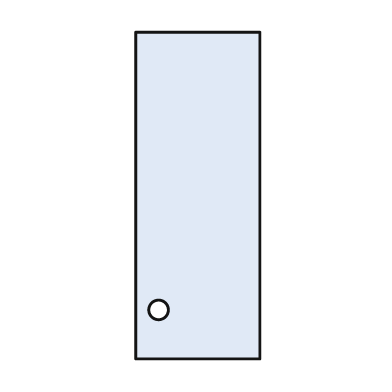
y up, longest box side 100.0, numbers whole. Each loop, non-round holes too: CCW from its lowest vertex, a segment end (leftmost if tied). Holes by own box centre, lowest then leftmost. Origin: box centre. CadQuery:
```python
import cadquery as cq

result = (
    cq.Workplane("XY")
    .moveTo(-19.0, -50.0)
    .lineTo(19.0, -50.0)
    .lineTo(19.0, 50.0)
    .lineTo(-19.0, 50.0)
    .close()
    .moveTo(-12.0, -35.0)
    .circle(3.0)
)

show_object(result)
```